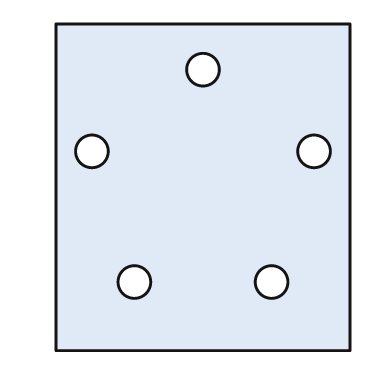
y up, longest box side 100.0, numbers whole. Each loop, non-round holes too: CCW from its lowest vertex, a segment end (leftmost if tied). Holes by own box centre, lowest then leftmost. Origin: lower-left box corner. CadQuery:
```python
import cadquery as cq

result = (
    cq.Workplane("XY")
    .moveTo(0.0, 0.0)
    .lineTo(90.0, 0.0)
    .lineTo(90.0, 100.0)
    .lineTo(0.0, 100.0)
    .close()
    .moveTo(24.0, 21.0)
    .circle(5.0)
    .moveTo(66.0, 21.0)
    .circle(5.0)
    .moveTo(11.0, 61.0)
    .circle(5.0)
    .moveTo(79.0, 61.0)
    .circle(5.0)
    .moveTo(45.0, 86.0)
    .circle(5.0)
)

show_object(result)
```